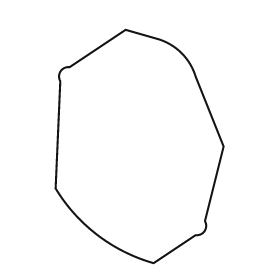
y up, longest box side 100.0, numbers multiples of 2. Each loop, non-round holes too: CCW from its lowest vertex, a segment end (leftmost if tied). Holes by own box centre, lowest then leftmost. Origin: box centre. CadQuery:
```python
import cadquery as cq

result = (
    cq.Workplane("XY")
    .moveTo(6.0, -50.0)
    .lineTo(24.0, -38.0)
    .threePointArc((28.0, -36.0), (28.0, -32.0))
    .lineTo(36.0, 0.0)
    .lineTo(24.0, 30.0)
    .threePointArc((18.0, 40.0), (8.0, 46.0))
    .lineTo(-6.0, 50.0)
    .lineTo(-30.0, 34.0)
    .threePointArc((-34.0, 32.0), (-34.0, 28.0))
    .lineTo(-36.0, -18.0)
    .threePointArc((-18.0, -38.0), (6.0, -50.0))
    .close()
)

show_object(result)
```